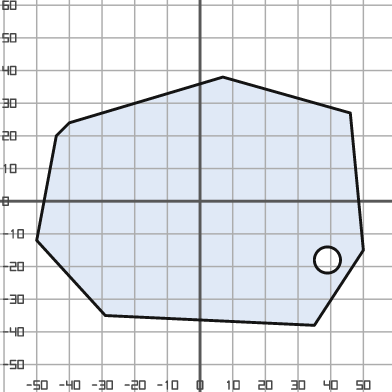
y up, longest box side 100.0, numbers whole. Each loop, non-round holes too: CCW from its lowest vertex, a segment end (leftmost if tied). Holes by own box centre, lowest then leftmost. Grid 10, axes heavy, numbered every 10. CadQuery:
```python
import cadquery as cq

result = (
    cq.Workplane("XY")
    .moveTo(35.0, -38.0)
    .lineTo(50.0, -15.0)
    .lineTo(46.0, 27.0)
    .lineTo(7.0, 38.0)
    .lineTo(-40.0, 24.0)
    .lineTo(-44.0, 20.0)
    .lineTo(-50.0, -12.0)
    .lineTo(-29.0, -35.0)
    .close()
    .moveTo(39.0, -18.0)
    .circle(4.0)
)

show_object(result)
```